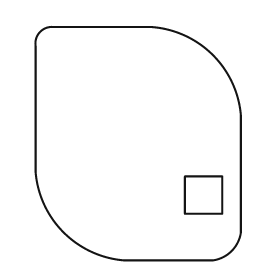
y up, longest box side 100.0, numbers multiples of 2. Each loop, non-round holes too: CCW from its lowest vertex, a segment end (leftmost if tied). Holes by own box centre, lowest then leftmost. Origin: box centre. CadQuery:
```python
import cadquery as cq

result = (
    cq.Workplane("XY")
    .moveTo(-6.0, -50.0)
    .lineTo(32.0, -50.0)
    .threePointArc((40.0, -46.0), (44.0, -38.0))
    .lineTo(44.0, 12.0)
    .threePointArc((32.0, 38.0), (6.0, 50.0))
    .lineTo(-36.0, 50.0)
    .threePointArc((-42.0, 48.0), (-44.0, 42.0))
    .lineTo(-44.0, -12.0)
    .threePointArc((-32.0, -38.0), (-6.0, -50.0))
    .close()
    .moveTo(20.0, -30.0)
    .lineTo(36.0, -30.0)
    .lineTo(36.0, -14.0)
    .lineTo(20.0, -14.0)
    .close()
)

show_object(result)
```